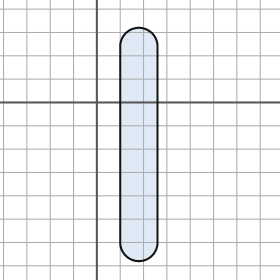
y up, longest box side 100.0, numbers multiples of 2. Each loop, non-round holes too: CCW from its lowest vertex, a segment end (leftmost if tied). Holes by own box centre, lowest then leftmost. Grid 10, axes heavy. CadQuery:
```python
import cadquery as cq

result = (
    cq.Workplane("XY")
    .moveTo(10.0, -60.0)
    .threePointArc((18.0, -68.0), (26.0, -60.0))
    .lineTo(26.0, 24.0)
    .threePointArc((18.0, 32.0), (10.0, 24.0))
    .close()
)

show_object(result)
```